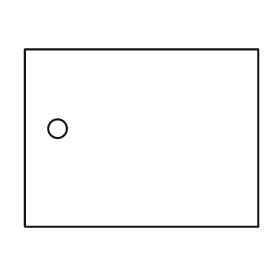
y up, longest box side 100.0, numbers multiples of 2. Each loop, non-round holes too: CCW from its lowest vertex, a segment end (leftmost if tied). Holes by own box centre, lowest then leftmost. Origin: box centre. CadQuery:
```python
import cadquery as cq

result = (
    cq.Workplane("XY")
    .moveTo(-50.0, -38.0)
    .lineTo(50.0, -38.0)
    .lineTo(50.0, 38.0)
    .lineTo(-50.0, 38.0)
    .close()
    .moveTo(-36.0, 4.0)
    .circle(4.0)
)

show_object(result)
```